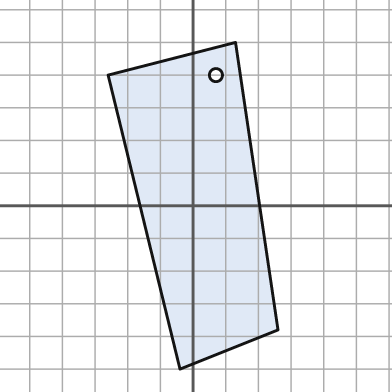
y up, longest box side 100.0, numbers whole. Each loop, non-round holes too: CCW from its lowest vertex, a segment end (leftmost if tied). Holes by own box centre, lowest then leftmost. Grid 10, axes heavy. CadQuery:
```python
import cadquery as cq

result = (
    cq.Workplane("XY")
    .moveTo(-4.0, -50.0)
    .lineTo(26.0, -38.0)
    .lineTo(13.0, 50.0)
    .lineTo(-26.0, 40.0)
    .close()
    .moveTo(7.0, 40.0)
    .circle(2.0)
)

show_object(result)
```